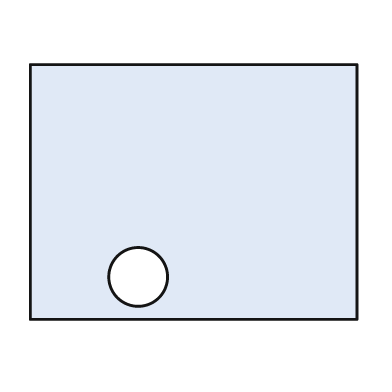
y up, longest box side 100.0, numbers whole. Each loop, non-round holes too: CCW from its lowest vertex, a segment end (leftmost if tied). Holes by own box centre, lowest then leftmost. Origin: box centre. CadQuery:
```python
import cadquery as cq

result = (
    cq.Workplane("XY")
    .moveTo(-50.0, -39.0)
    .lineTo(50.0, -39.0)
    .lineTo(50.0, 39.0)
    .lineTo(-50.0, 39.0)
    .close()
    .moveTo(-17.0, -26.0)
    .circle(9.0)
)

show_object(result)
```